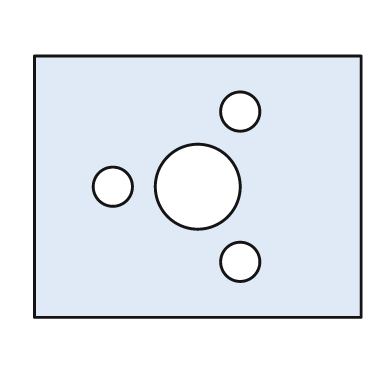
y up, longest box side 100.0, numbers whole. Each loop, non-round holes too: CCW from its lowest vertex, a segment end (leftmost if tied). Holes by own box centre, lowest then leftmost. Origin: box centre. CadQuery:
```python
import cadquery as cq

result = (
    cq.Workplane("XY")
    .moveTo(-50.0, -40.0)
    .lineTo(50.0, -40.0)
    .lineTo(50.0, 40.0)
    .lineTo(-50.0, 40.0)
    .close()
    .moveTo(13.0, -23.0)
    .circle(6.0)
    .moveTo(-26.0, 0.0)
    .circle(6.0)
    .moveTo(0.0, 0.0)
    .circle(13.0)
    .moveTo(13.0, 23.0)
    .circle(6.0)
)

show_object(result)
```